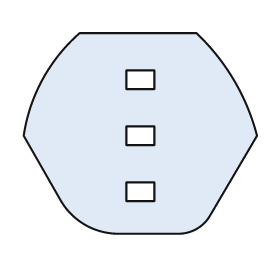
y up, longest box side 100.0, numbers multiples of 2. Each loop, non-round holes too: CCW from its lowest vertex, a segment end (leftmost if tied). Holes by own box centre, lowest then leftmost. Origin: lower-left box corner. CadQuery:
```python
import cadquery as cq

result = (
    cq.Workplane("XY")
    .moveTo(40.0, 0.0)
    .lineTo(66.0, 0.0)
    .threePointArc((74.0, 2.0), (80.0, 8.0))
    .lineTo(100.0, 42.0)
    .threePointArc((90.0, 66.0), (74.0, 86.0))
    .lineTo(24.0, 86.0)
    .threePointArc((8.0, 66.0), (0.0, 42.0))
    .lineTo(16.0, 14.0)
    .threePointArc((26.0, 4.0), (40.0, 0.0))
    .close()
    .moveTo(44.0, 14.0)
    .lineTo(56.0, 14.0)
    .lineTo(56.0, 22.0)
    .lineTo(44.0, 22.0)
    .close()
    .moveTo(44.0, 38.0)
    .lineTo(56.0, 38.0)
    .lineTo(56.0, 46.0)
    .lineTo(44.0, 46.0)
    .close()
    .moveTo(44.0, 62.0)
    .lineTo(56.0, 62.0)
    .lineTo(56.0, 70.0)
    .lineTo(44.0, 70.0)
    .close()
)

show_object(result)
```